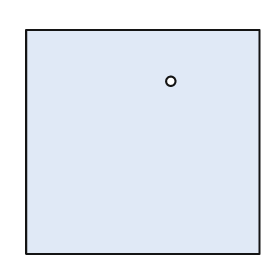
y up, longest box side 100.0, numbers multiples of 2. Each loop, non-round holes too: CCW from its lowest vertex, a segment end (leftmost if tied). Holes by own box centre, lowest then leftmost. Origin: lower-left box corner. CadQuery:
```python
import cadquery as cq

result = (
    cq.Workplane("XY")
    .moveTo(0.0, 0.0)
    .lineTo(100.0, 0.0)
    .lineTo(100.0, 96.0)
    .lineTo(0.0, 96.0)
    .close()
    .moveTo(62.0, 74.0)
    .circle(2.0)
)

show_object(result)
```